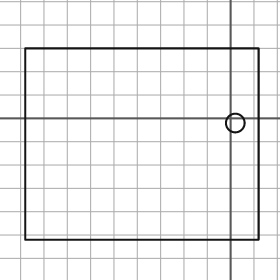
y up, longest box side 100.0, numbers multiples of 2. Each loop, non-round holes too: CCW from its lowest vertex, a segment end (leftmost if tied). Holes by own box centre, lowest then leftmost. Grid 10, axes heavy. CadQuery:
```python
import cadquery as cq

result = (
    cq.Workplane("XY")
    .moveTo(-88.0, -52.0)
    .lineTo(12.0, -52.0)
    .lineTo(12.0, 30.0)
    .lineTo(-88.0, 30.0)
    .close()
    .moveTo(2.0, -2.0)
    .circle(4.0)
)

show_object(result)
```